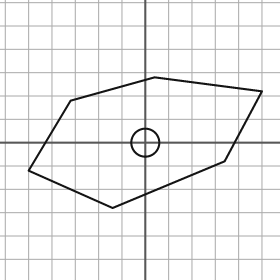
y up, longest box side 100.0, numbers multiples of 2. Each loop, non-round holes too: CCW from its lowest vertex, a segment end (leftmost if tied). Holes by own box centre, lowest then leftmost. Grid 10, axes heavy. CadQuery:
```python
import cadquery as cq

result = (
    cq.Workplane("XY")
    .moveTo(-14.0, -28.0)
    .lineTo(34.0, -8.0)
    .lineTo(50.0, 22.0)
    .lineTo(4.0, 28.0)
    .lineTo(-32.0, 18.0)
    .lineTo(-50.0, -12.0)
    .close()
    .moveTo(0.0, 0.0)
    .circle(6.0)
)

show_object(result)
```